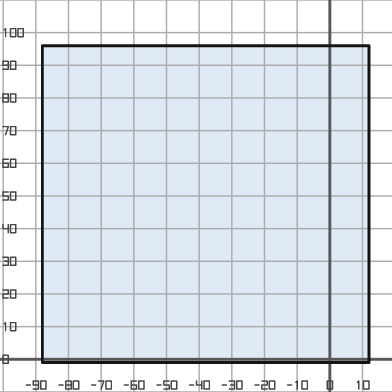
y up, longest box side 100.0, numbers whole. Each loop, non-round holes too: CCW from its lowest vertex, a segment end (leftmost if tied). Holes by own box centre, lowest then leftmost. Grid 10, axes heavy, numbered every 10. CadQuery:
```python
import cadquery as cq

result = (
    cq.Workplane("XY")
    .moveTo(-88.0, -1.0)
    .lineTo(12.0, -1.0)
    .lineTo(12.0, 96.0)
    .lineTo(-88.0, 96.0)
    .close()
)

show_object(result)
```